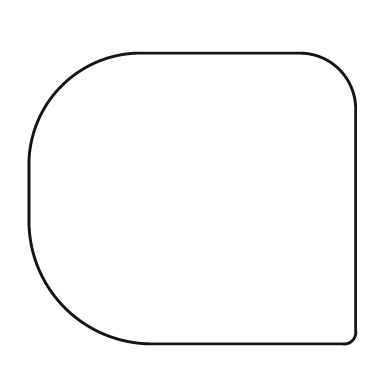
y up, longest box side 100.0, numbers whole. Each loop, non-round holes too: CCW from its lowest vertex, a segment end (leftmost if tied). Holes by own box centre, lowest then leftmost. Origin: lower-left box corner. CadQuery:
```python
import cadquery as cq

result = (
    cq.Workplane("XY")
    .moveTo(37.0, 0.0)
    .lineTo(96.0, 0.0)
    .threePointArc((99.0, 1.0), (100.0, 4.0))
    .lineTo(100.0, 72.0)
    .threePointArc((95.0, 84.0), (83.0, 89.0))
    .lineTo(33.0, 89.0)
    .threePointArc((10.0, 79.0), (0.0, 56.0))
    .lineTo(0.0, 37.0)
    .threePointArc((11.0, 11.0), (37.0, 0.0))
    .close()
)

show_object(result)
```